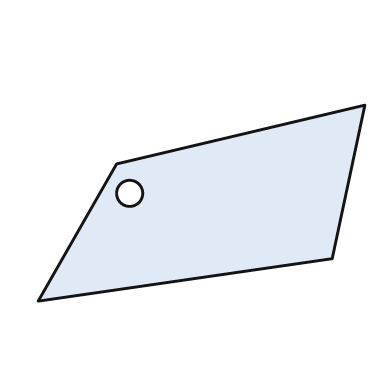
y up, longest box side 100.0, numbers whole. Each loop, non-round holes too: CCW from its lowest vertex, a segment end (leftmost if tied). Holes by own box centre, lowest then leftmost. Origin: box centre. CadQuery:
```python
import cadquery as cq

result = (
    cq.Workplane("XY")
    .moveTo(-50.0, -30.0)
    .lineTo(40.0, -17.0)
    .lineTo(50.0, 30.0)
    .lineTo(-26.0, 12.0)
    .close()
    .moveTo(-22.0, 3.0)
    .circle(4.0)
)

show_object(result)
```